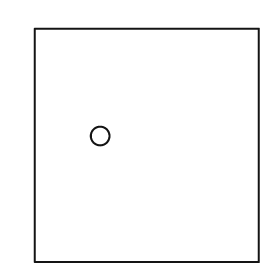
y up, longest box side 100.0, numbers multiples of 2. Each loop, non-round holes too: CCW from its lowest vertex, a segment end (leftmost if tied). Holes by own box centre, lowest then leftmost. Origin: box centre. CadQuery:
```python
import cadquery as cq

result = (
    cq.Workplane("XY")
    .moveTo(-48.0, -50.0)
    .lineTo(48.0, -50.0)
    .lineTo(48.0, 50.0)
    .lineTo(-48.0, 50.0)
    .close()
    .moveTo(-20.0, 4.0)
    .circle(4.0)
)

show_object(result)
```